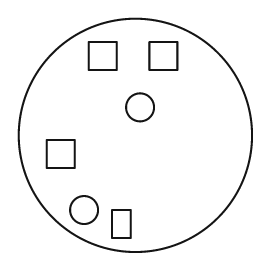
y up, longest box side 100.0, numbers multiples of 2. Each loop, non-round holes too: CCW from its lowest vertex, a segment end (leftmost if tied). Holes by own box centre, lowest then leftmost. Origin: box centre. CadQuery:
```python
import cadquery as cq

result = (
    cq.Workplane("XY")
    .moveTo(0.0, 0.0)
    .circle(50.0)
    .moveTo(-10.0, -44.0)
    .lineTo(-2.0, -44.0)
    .lineTo(-2.0, -32.0)
    .lineTo(-10.0, -32.0)
    .close()
    .moveTo(-22.0, -32.0)
    .circle(6.0)
    .moveTo(-38.0, -14.0)
    .lineTo(-26.0, -14.0)
    .lineTo(-26.0, -2.0)
    .lineTo(-38.0, -2.0)
    .close()
    .moveTo(2.0, 12.0)
    .circle(6.0)
    .moveTo(-20.0, 28.0)
    .lineTo(-8.0, 28.0)
    .lineTo(-8.0, 40.0)
    .lineTo(-20.0, 40.0)
    .close()
    .moveTo(6.0, 28.0)
    .lineTo(18.0, 28.0)
    .lineTo(18.0, 40.0)
    .lineTo(6.0, 40.0)
    .close()
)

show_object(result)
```